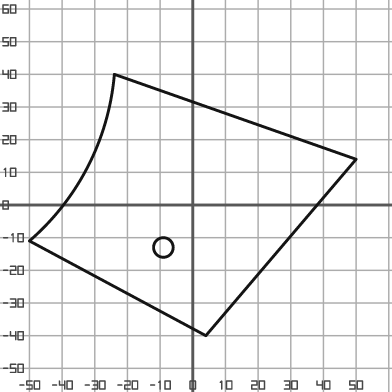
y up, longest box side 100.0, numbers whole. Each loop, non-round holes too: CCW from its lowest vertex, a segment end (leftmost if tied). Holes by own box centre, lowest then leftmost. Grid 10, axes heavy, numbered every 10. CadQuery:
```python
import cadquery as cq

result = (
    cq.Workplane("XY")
    .moveTo(4.0, -40.0)
    .lineTo(50.0, 14.0)
    .lineTo(-24.0, 40.0)
    .threePointArc((-32.0, 12.0), (-50.0, -11.0))
    .close()
    .moveTo(-9.0, -13.0)
    .circle(3.0)
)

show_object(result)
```